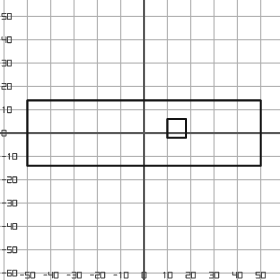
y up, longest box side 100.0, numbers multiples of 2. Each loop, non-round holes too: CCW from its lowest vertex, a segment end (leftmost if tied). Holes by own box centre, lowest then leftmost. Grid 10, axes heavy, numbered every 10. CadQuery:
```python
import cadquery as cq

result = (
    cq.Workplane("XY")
    .moveTo(-50.0, -14.0)
    .lineTo(50.0, -14.0)
    .lineTo(50.0, 14.0)
    .lineTo(-50.0, 14.0)
    .close()
    .moveTo(10.0, -2.0)
    .lineTo(18.0, -2.0)
    .lineTo(18.0, 6.0)
    .lineTo(10.0, 6.0)
    .close()
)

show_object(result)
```